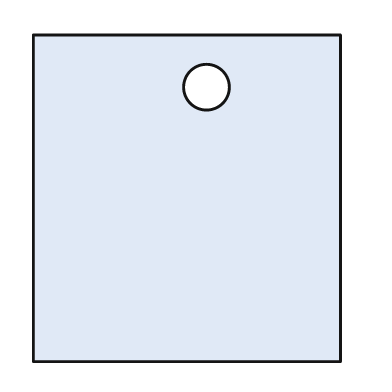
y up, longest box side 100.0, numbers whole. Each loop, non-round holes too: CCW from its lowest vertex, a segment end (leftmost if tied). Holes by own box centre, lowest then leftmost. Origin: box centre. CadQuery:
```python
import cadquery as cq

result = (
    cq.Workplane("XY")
    .moveTo(-47.0, -50.0)
    .lineTo(47.0, -50.0)
    .lineTo(47.0, 50.0)
    .lineTo(-47.0, 50.0)
    .close()
    .moveTo(6.0, 34.0)
    .circle(7.0)
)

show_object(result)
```